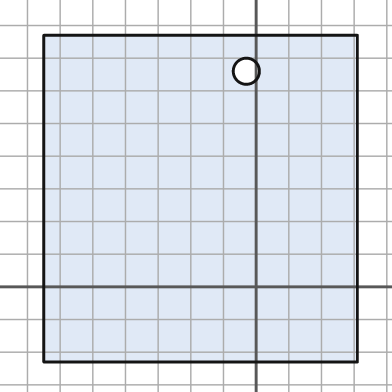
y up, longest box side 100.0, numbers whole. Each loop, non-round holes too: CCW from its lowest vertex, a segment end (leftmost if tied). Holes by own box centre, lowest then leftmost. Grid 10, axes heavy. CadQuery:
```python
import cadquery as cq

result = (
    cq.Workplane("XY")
    .moveTo(-65.0, -23.0)
    .lineTo(31.0, -23.0)
    .lineTo(31.0, 77.0)
    .lineTo(-65.0, 77.0)
    .close()
    .moveTo(-3.0, 66.0)
    .circle(4.0)
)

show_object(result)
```